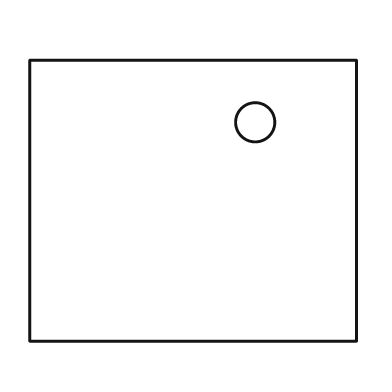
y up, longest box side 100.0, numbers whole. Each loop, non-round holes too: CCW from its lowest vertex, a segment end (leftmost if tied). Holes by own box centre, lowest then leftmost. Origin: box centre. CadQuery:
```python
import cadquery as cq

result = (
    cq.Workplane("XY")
    .moveTo(-50.0, -43.0)
    .lineTo(50.0, -43.0)
    .lineTo(50.0, 43.0)
    .lineTo(-50.0, 43.0)
    .close()
    .moveTo(19.0, 24.0)
    .circle(6.0)
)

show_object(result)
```